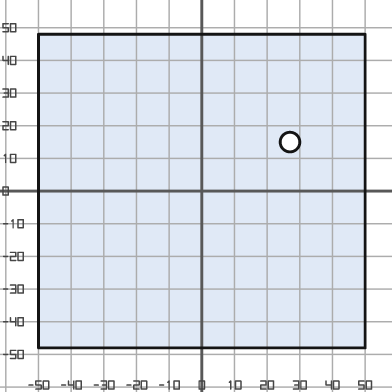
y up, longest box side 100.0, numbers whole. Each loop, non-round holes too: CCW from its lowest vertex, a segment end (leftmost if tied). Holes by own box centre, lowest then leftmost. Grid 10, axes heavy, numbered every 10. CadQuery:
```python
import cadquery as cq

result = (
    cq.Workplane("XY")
    .moveTo(-50.0, -48.0)
    .lineTo(50.0, -48.0)
    .lineTo(50.0, 48.0)
    .lineTo(-50.0, 48.0)
    .close()
    .moveTo(27.0, 15.0)
    .circle(3.0)
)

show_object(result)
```